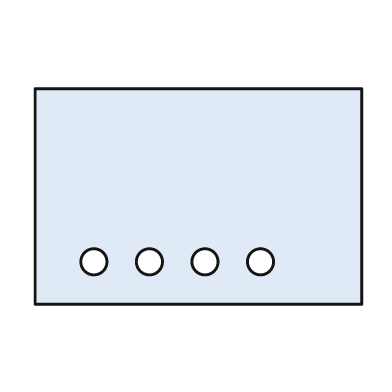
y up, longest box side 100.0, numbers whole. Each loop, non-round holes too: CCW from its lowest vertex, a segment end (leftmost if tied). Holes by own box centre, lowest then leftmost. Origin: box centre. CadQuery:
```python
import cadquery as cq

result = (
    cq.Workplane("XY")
    .moveTo(-50.0, -33.0)
    .lineTo(50.0, -33.0)
    .lineTo(50.0, 33.0)
    .lineTo(-50.0, 33.0)
    .close()
    .moveTo(-32.0, -20.0)
    .circle(4.0)
    .moveTo(-15.0, -20.0)
    .circle(4.0)
    .moveTo(2.0, -20.0)
    .circle(4.0)
    .moveTo(19.0, -20.0)
    .circle(4.0)
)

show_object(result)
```